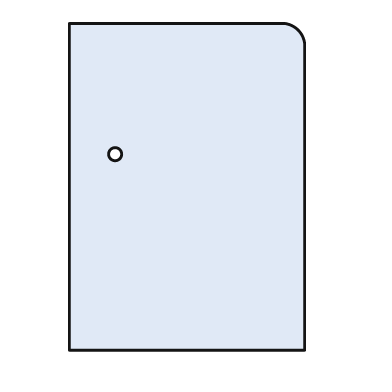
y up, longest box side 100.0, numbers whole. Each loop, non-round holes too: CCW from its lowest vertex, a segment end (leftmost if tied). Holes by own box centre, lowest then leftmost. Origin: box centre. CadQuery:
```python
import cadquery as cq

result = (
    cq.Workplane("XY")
    .moveTo(-36.0, -50.0)
    .lineTo(36.0, -50.0)
    .lineTo(36.0, 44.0)
    .threePointArc((34.0, 48.0), (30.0, 50.0))
    .lineTo(-36.0, 50.0)
    .close()
    .moveTo(-22.0, 10.0)
    .circle(2.0)
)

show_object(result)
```